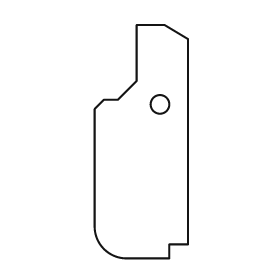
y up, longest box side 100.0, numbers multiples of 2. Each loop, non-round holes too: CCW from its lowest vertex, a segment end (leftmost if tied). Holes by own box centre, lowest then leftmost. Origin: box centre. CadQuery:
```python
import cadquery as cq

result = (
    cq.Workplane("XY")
    .moveTo(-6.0, -50.0)
    .lineTo(12.0, -50.0)
    .lineTo(12.0, -44.0)
    .lineTo(20.0, -44.0)
    .lineTo(20.0, 44.0)
    .lineTo(10.0, 50.0)
    .lineTo(-2.0, 50.0)
    .lineTo(-2.0, 26.0)
    .lineTo(-10.0, 18.0)
    .lineTo(-16.0, 18.0)
    .lineTo(-20.0, 14.0)
    .lineTo(-20.0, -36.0)
    .threePointArc((-16.0, -46.0), (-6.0, -50.0))
    .close()
    .moveTo(8.0, 16.0)
    .circle(4.0)
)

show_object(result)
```